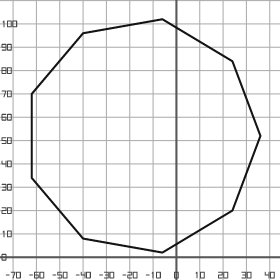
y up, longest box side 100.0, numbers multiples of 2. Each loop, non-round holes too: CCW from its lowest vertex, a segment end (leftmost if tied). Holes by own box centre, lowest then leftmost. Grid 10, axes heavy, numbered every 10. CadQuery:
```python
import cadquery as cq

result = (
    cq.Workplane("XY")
    .moveTo(-6.0, 2.0)
    .lineTo(24.0, 20.0)
    .lineTo(36.0, 52.0)
    .lineTo(24.0, 84.0)
    .lineTo(-6.0, 102.0)
    .lineTo(-40.0, 96.0)
    .lineTo(-62.0, 70.0)
    .lineTo(-62.0, 34.0)
    .lineTo(-40.0, 8.0)
    .close()
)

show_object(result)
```